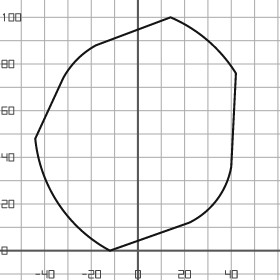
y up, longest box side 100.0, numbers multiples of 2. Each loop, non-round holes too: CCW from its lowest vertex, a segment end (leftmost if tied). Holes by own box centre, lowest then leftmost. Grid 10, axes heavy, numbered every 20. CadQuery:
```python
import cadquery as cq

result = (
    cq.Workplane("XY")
    .moveTo(-12.0, 0.0)
    .lineTo(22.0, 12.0)
    .threePointArc((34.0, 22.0), (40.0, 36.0))
    .lineTo(42.0, 76.0)
    .threePointArc((30.0, 90.0), (14.0, 100.0))
    .lineTo(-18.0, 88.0)
    .threePointArc((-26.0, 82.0), (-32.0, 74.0))
    .lineTo(-44.0, 48.0)
    .threePointArc((-34.0, 20.0), (-12.0, 0.0))
    .close()
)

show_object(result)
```